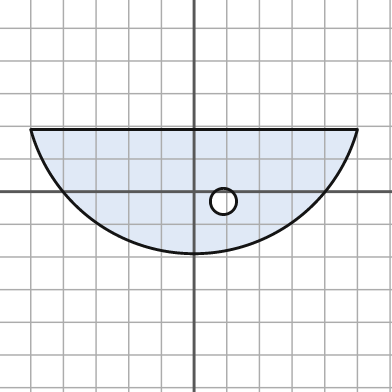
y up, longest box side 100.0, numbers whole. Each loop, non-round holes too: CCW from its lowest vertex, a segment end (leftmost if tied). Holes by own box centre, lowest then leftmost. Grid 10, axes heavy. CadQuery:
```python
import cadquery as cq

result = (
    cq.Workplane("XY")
    .moveTo(-50.0, 19.0)
    .threePointArc((0.0, -19.0), (50.0, 19.0))
    .close()
    .moveTo(9.0, -3.0)
    .circle(4.0)
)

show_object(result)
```